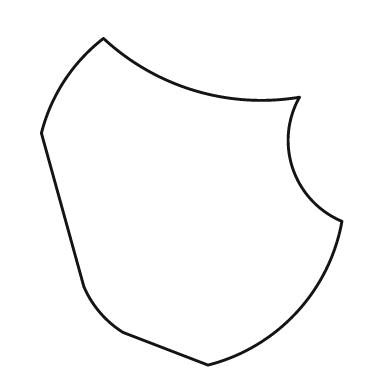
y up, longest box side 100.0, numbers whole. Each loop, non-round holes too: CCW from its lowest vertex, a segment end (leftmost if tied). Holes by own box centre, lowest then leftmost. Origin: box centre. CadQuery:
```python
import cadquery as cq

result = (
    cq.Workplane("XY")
    .moveTo(5.0, -50.0)
    .threePointArc((32.0, -34.0), (46.0, -6.0))
    .threePointArc((31.0, 10.0), (33.0, 32.0))
    .threePointArc((1.0, 34.0), (-27.0, 50.0))
    .threePointArc((-39.0, 37.0), (-46.0, 21.0))
    .lineTo(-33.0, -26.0)
    .threePointArc((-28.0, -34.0), (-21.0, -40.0))
    .close()
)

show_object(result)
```